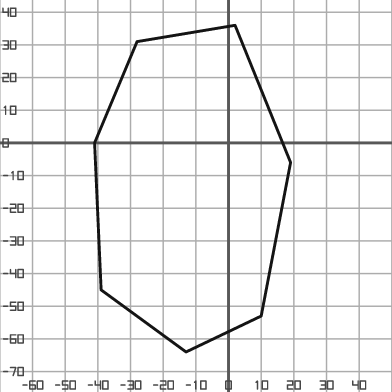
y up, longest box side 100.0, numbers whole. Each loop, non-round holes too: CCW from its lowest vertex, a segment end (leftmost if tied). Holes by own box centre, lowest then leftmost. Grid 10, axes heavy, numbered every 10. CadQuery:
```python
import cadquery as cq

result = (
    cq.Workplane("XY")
    .moveTo(-13.0, -64.0)
    .lineTo(10.0, -53.0)
    .lineTo(19.0, -6.0)
    .lineTo(2.0, 36.0)
    .lineTo(-28.0, 31.0)
    .lineTo(-41.0, 0.0)
    .lineTo(-39.0, -45.0)
    .close()
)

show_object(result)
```